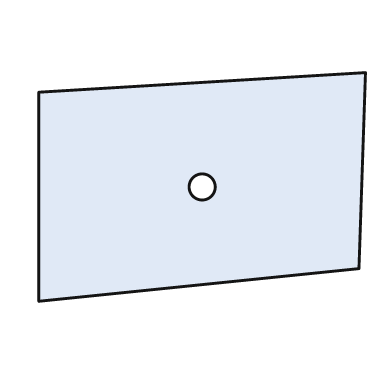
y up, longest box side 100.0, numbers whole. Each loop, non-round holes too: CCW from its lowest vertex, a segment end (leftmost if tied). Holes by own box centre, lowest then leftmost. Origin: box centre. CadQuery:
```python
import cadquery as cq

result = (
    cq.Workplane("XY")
    .moveTo(-50.0, -35.0)
    .lineTo(48.0, -25.0)
    .lineTo(50.0, 35.0)
    .lineTo(-50.0, 29.0)
    .close()
    .moveTo(0.0, 0.0)
    .circle(4.0)
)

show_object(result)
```